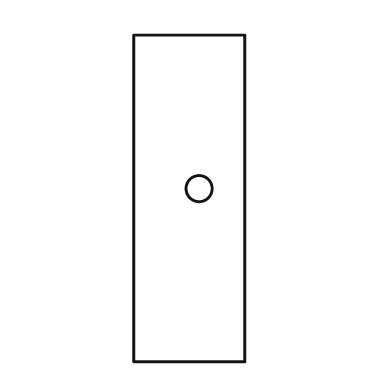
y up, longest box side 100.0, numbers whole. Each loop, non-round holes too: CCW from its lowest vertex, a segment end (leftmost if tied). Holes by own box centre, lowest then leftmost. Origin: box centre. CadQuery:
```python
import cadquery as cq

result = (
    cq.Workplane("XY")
    .moveTo(-17.0, -50.0)
    .lineTo(17.0, -50.0)
    .lineTo(17.0, 50.0)
    .lineTo(-17.0, 50.0)
    .close()
    .moveTo(3.0, 3.0)
    .circle(4.0)
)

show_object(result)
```